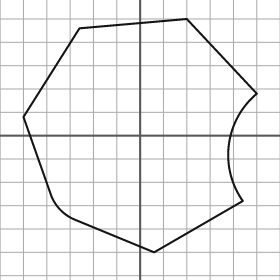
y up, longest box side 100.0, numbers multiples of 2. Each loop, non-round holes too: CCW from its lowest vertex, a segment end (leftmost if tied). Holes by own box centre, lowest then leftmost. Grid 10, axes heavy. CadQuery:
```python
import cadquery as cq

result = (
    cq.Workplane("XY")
    .moveTo(6.0, -50.0)
    .lineTo(44.0, -28.0)
    .threePointArc((38.0, -4.0), (50.0, 18.0))
    .lineTo(20.0, 50.0)
    .lineTo(-26.0, 46.0)
    .lineTo(-50.0, 8.0)
    .lineTo(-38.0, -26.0)
    .threePointArc((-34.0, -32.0), (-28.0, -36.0))
    .close()
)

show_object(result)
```